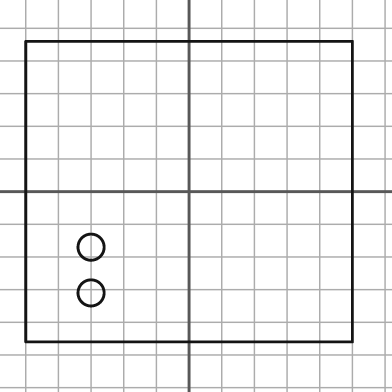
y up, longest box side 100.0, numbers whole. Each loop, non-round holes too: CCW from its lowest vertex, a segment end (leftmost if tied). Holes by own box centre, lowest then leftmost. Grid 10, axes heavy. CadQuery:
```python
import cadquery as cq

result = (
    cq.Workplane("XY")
    .moveTo(-50.0, -46.0)
    .lineTo(50.0, -46.0)
    .lineTo(50.0, 46.0)
    .lineTo(-50.0, 46.0)
    .close()
    .moveTo(-30.0, -31.0)
    .circle(4.0)
    .moveTo(-30.0, -17.0)
    .circle(4.0)
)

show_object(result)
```